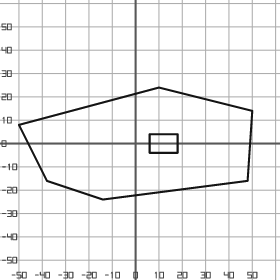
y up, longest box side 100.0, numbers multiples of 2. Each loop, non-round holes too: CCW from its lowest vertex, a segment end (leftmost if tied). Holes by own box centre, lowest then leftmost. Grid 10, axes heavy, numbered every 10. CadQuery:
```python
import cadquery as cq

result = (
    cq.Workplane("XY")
    .moveTo(-14.0, -24.0)
    .lineTo(48.0, -16.0)
    .lineTo(50.0, 14.0)
    .lineTo(10.0, 24.0)
    .lineTo(-50.0, 8.0)
    .lineTo(-38.0, -16.0)
    .close()
    .moveTo(6.0, -4.0)
    .lineTo(18.0, -4.0)
    .lineTo(18.0, 4.0)
    .lineTo(6.0, 4.0)
    .close()
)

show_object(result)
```